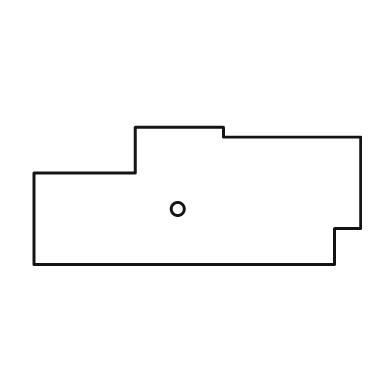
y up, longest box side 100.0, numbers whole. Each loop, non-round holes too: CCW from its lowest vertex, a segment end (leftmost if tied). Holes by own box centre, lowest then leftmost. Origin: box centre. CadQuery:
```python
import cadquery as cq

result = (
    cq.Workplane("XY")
    .moveTo(-50.0, -21.0)
    .lineTo(42.0, -21.0)
    .lineTo(42.0, -10.0)
    .lineTo(50.0, -10.0)
    .lineTo(50.0, 18.0)
    .lineTo(8.0, 18.0)
    .lineTo(8.0, 21.0)
    .lineTo(-19.0, 21.0)
    .lineTo(-19.0, 7.0)
    .lineTo(-50.0, 7.0)
    .close()
    .moveTo(-6.0, -4.0)
    .circle(2.0)
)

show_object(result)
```